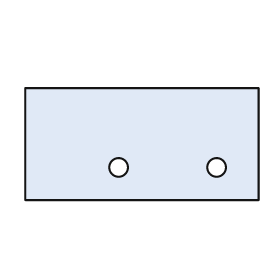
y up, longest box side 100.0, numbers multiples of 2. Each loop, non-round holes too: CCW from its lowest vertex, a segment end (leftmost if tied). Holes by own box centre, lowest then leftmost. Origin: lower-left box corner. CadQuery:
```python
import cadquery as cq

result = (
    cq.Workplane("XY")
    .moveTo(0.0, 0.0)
    .lineTo(100.0, 0.0)
    .lineTo(100.0, 48.0)
    .lineTo(0.0, 48.0)
    .close()
    .moveTo(40.0, 14.0)
    .circle(4.0)
    .moveTo(82.0, 14.0)
    .circle(4.0)
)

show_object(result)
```